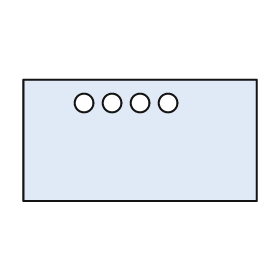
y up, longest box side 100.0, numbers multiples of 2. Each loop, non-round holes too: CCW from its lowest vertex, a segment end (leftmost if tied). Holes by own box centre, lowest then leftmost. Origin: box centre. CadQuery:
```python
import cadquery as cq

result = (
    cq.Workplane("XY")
    .moveTo(-50.0, -26.0)
    .lineTo(50.0, -26.0)
    .lineTo(50.0, 26.0)
    .lineTo(-50.0, 26.0)
    .close()
    .moveTo(-24.0, 16.0)
    .circle(4.0)
    .moveTo(-12.0, 16.0)
    .circle(4.0)
    .moveTo(0.0, 16.0)
    .circle(4.0)
    .moveTo(12.0, 16.0)
    .circle(4.0)
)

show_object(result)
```